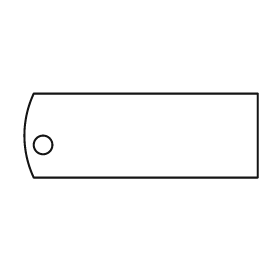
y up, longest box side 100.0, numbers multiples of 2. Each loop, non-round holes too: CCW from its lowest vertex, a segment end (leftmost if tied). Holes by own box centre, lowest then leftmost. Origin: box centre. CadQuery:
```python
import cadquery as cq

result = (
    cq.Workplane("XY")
    .moveTo(-46.0, -18.0)
    .lineTo(50.0, -18.0)
    .lineTo(50.0, 18.0)
    .lineTo(-46.0, 18.0)
    .threePointArc((-50.0, 0.0), (-46.0, -18.0))
    .close()
    .moveTo(-42.0, -4.0)
    .circle(4.0)
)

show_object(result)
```